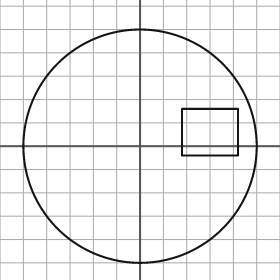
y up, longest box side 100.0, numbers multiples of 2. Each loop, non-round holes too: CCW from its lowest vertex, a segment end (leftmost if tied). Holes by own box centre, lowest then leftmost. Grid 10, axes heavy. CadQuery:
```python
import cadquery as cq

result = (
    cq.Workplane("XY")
    .moveTo(0.0, 0.0)
    .circle(50.0)
    .moveTo(18.0, -4.0)
    .lineTo(42.0, -4.0)
    .lineTo(42.0, 16.0)
    .lineTo(18.0, 16.0)
    .close()
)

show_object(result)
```